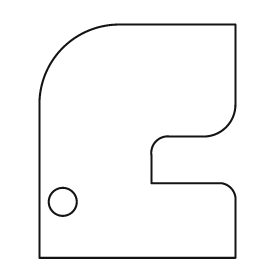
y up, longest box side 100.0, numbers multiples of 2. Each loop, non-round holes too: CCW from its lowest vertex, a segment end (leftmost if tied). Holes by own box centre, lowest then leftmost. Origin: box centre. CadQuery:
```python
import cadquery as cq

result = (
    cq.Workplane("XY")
    .moveTo(-42.0, -50.0)
    .lineTo(42.0, -50.0)
    .lineTo(42.0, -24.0)
    .threePointArc((40.0, -20.0), (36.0, -18.0))
    .lineTo(6.0, -18.0)
    .lineTo(6.0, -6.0)
    .threePointArc((8.0, 0.0), (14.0, 2.0))
    .lineTo(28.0, 2.0)
    .threePointArc((38.0, 6.0), (42.0, 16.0))
    .lineTo(42.0, 50.0)
    .lineTo(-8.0, 50.0)
    .threePointArc((-32.0, 40.0), (-42.0, 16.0))
    .close()
    .moveTo(-32.0, -26.0)
    .circle(6.0)
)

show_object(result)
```